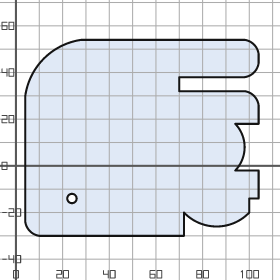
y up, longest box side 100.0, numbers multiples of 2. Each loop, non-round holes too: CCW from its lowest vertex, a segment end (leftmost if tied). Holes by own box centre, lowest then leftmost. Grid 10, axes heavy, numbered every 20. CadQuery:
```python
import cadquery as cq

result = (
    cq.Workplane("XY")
    .moveTo(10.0, -30.0)
    .lineTo(72.0, -30.0)
    .lineTo(72.0, -20.0)
    .threePointArc((86.0, -26.0), (100.0, -20.0))
    .lineTo(100.0, -14.0)
    .lineTo(104.0, -14.0)
    .lineTo(104.0, -2.0)
    .lineTo(94.0, -2.0)
    .threePointArc((98.0, 8.0), (94.0, 18.0))
    .lineTo(104.0, 18.0)
    .lineTo(104.0, 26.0)
    .threePointArc((102.0, 30.0), (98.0, 32.0))
    .lineTo(70.0, 32.0)
    .lineTo(70.0, 38.0)
    .lineTo(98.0, 38.0)
    .threePointArc((102.0, 40.0), (104.0, 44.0))
    .lineTo(104.0, 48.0)
    .threePointArc((102.0, 52.0), (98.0, 54.0))
    .lineTo(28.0, 54.0)
    .threePointArc((12.0, 46.0), (4.0, 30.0))
    .lineTo(4.0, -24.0)
    .threePointArc((6.0, -28.0), (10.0, -30.0))
    .close()
    .moveTo(24.0, -14.0)
    .circle(2.0)
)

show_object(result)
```